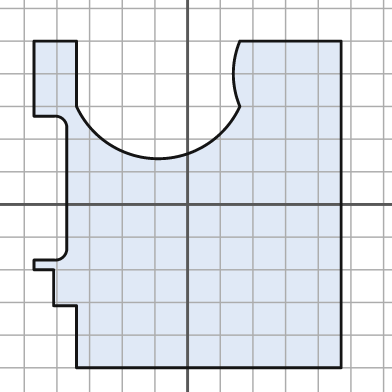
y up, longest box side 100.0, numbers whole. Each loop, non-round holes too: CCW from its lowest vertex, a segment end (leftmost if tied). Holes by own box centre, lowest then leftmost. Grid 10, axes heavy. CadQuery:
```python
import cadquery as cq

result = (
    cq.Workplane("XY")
    .moveTo(-34.0, -50.0)
    .lineTo(47.0, -50.0)
    .lineTo(47.0, 50.0)
    .lineTo(16.0, 50.0)
    .threePointArc((14.0, 40.0), (16.0, 30.0))
    .threePointArc((-9.0, 14.0), (-34.0, 30.0))
    .lineTo(-34.0, 50.0)
    .lineTo(-47.0, 50.0)
    .lineTo(-47.0, 27.0)
    .lineTo(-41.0, 27.0)
    .threePointArc((-38.0, 26.0), (-37.0, 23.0))
    .lineTo(-37.0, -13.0)
    .threePointArc((-38.0, -16.0), (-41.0, -17.0))
    .lineTo(-47.0, -17.0)
    .lineTo(-47.0, -20.0)
    .lineTo(-41.0, -20.0)
    .lineTo(-41.0, -31.0)
    .lineTo(-34.0, -31.0)
    .close()
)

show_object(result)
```